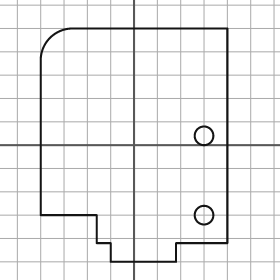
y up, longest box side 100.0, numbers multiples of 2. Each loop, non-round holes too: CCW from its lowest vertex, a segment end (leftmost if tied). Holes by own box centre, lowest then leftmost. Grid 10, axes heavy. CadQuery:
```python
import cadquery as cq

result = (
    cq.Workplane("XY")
    .moveTo(-10.0, -50.0)
    .lineTo(18.0, -50.0)
    .lineTo(18.0, -42.0)
    .lineTo(40.0, -42.0)
    .lineTo(40.0, 50.0)
    .lineTo(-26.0, 50.0)
    .threePointArc((-36.0, 46.0), (-40.0, 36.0))
    .lineTo(-40.0, -30.0)
    .lineTo(-16.0, -30.0)
    .lineTo(-16.0, -42.0)
    .lineTo(-10.0, -42.0)
    .close()
    .moveTo(30.0, -30.0)
    .circle(4.0)
    .moveTo(30.0, 4.0)
    .circle(4.0)
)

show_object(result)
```